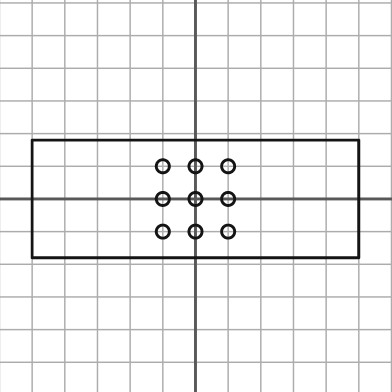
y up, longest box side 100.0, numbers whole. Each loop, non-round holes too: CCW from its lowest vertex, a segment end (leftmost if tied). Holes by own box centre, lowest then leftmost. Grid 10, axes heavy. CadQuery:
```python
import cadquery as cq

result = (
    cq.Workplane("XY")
    .moveTo(-50.0, -18.0)
    .lineTo(50.0, -18.0)
    .lineTo(50.0, 18.0)
    .lineTo(-50.0, 18.0)
    .close()
    .moveTo(-10.0, -10.0)
    .circle(2.0)
    .moveTo(0.0, -10.0)
    .circle(2.0)
    .moveTo(10.0, -10.0)
    .circle(2.0)
    .moveTo(-10.0, 0.0)
    .circle(2.0)
    .moveTo(0.0, 0.0)
    .circle(2.0)
    .moveTo(10.0, 0.0)
    .circle(2.0)
    .moveTo(-10.0, 10.0)
    .circle(2.0)
    .moveTo(0.0, 10.0)
    .circle(2.0)
    .moveTo(10.0, 10.0)
    .circle(2.0)
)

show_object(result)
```